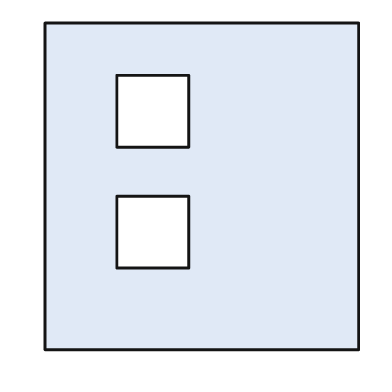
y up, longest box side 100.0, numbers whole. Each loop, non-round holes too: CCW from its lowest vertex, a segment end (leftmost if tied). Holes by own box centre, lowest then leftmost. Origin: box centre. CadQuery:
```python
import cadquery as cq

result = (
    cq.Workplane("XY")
    .moveTo(-48.0, -50.0)
    .lineTo(48.0, -50.0)
    .lineTo(48.0, 50.0)
    .lineTo(-48.0, 50.0)
    .close()
    .moveTo(-26.0, -25.0)
    .lineTo(-4.0, -25.0)
    .lineTo(-4.0, -3.0)
    .lineTo(-26.0, -3.0)
    .close()
    .moveTo(-26.0, 12.0)
    .lineTo(-4.0, 12.0)
    .lineTo(-4.0, 34.0)
    .lineTo(-26.0, 34.0)
    .close()
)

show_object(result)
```